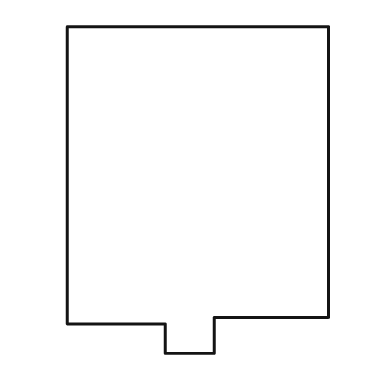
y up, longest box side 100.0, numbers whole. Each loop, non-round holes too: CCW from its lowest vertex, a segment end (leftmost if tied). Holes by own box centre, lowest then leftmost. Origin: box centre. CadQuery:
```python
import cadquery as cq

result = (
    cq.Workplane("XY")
    .moveTo(-10.0, -50.0)
    .lineTo(5.0, -50.0)
    .lineTo(5.0, -39.0)
    .lineTo(40.0, -39.0)
    .lineTo(40.0, 50.0)
    .lineTo(-40.0, 50.0)
    .lineTo(-40.0, -41.0)
    .lineTo(-10.0, -41.0)
    .close()
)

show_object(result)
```